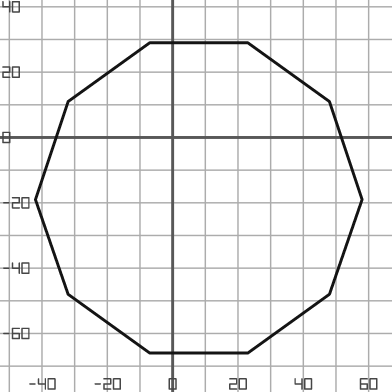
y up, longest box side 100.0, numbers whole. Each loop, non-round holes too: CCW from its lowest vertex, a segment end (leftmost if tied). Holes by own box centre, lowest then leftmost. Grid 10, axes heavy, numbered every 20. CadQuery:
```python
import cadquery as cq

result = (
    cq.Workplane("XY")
    .moveTo(-7.0, -66.0)
    .lineTo(23.0, -66.0)
    .lineTo(48.0, -48.0)
    .lineTo(58.0, -19.0)
    .lineTo(48.0, 11.0)
    .lineTo(23.0, 29.0)
    .lineTo(-7.0, 29.0)
    .lineTo(-32.0, 11.0)
    .lineTo(-42.0, -19.0)
    .lineTo(-32.0, -48.0)
    .close()
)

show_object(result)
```